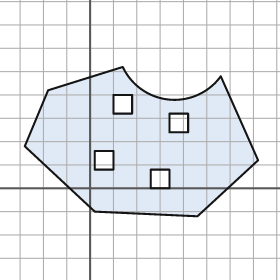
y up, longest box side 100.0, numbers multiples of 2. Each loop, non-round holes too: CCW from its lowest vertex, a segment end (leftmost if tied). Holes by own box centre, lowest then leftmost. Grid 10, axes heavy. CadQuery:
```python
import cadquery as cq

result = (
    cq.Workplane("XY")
    .moveTo(46.0, -12.0)
    .lineTo(72.0, 12.0)
    .lineTo(56.0, 48.0)
    .threePointArc((34.0, 38.0), (14.0, 52.0))
    .lineTo(-18.0, 42.0)
    .lineTo(-28.0, 18.0)
    .lineTo(2.0, -10.0)
    .close()
    .moveTo(26.0, 0.0)
    .lineTo(34.0, 0.0)
    .lineTo(34.0, 8.0)
    .lineTo(26.0, 8.0)
    .close()
    .moveTo(2.0, 8.0)
    .lineTo(10.0, 8.0)
    .lineTo(10.0, 16.0)
    .lineTo(2.0, 16.0)
    .close()
    .moveTo(34.0, 24.0)
    .lineTo(42.0, 24.0)
    .lineTo(42.0, 32.0)
    .lineTo(34.0, 32.0)
    .close()
    .moveTo(10.0, 32.0)
    .lineTo(18.0, 32.0)
    .lineTo(18.0, 40.0)
    .lineTo(10.0, 40.0)
    .close()
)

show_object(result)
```